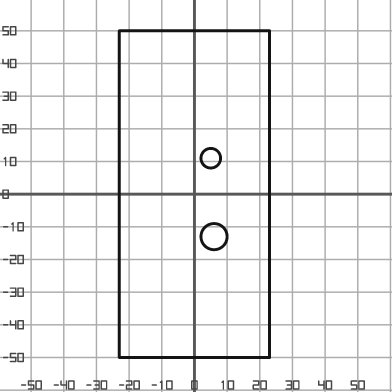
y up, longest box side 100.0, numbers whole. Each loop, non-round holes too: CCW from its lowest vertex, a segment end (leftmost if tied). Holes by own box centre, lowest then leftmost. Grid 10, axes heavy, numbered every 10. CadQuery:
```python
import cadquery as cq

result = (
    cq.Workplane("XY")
    .moveTo(-23.0, -50.0)
    .lineTo(23.0, -50.0)
    .lineTo(23.0, 50.0)
    .lineTo(-23.0, 50.0)
    .close()
    .moveTo(6.0, -13.0)
    .circle(4.0)
    .moveTo(5.0, 11.0)
    .circle(3.0)
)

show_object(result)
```